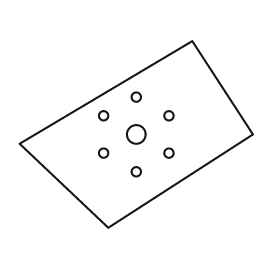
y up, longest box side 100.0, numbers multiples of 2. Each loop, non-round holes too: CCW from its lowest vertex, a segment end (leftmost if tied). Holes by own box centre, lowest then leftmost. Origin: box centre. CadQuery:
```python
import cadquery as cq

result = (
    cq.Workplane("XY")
    .moveTo(-12.0, -40.0)
    .lineTo(50.0, 0.0)
    .lineTo(24.0, 40.0)
    .lineTo(-50.0, -4.0)
    .close()
    .moveTo(0.0, -16.0)
    .circle(2.0)
    .moveTo(-14.0, -8.0)
    .circle(2.0)
    .moveTo(14.0, -8.0)
    .circle(2.0)
    .moveTo(0.0, 0.0)
    .circle(4.0)
    .moveTo(-14.0, 8.0)
    .circle(2.0)
    .moveTo(14.0, 8.0)
    .circle(2.0)
    .moveTo(0.0, 16.0)
    .circle(2.0)
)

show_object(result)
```